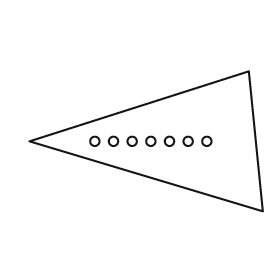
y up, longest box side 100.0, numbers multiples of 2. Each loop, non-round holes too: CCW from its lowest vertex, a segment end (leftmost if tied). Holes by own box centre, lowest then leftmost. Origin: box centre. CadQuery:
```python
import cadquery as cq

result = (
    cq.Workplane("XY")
    .moveTo(50.0, -30.0)
    .lineTo(44.0, 30.0)
    .lineTo(-50.0, 0.0)
    .close()
    .moveTo(-22.0, 0.0)
    .circle(2.0)
    .moveTo(-14.0, 0.0)
    .circle(2.0)
    .moveTo(-6.0, 0.0)
    .circle(2.0)
    .moveTo(2.0, 0.0)
    .circle(2.0)
    .moveTo(10.0, 0.0)
    .circle(2.0)
    .moveTo(18.0, 0.0)
    .circle(2.0)
    .moveTo(26.0, 0.0)
    .circle(2.0)
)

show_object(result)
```